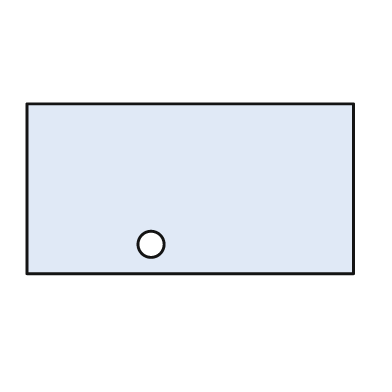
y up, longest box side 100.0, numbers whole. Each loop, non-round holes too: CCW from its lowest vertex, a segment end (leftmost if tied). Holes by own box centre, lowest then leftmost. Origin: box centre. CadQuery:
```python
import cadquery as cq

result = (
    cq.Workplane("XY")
    .moveTo(-50.0, -26.0)
    .lineTo(50.0, -26.0)
    .lineTo(50.0, 26.0)
    .lineTo(-50.0, 26.0)
    .close()
    .moveTo(-12.0, -17.0)
    .circle(4.0)
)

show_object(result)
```